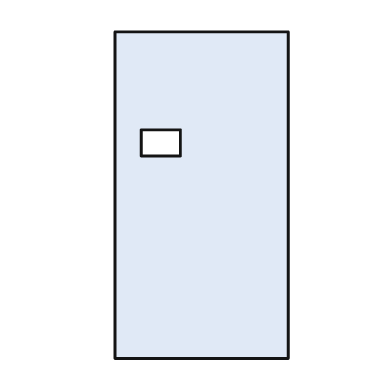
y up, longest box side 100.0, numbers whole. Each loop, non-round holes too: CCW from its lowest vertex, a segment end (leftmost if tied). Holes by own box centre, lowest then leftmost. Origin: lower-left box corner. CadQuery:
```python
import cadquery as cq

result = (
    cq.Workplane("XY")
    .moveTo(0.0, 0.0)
    .lineTo(53.0, 0.0)
    .lineTo(53.0, 100.0)
    .lineTo(0.0, 100.0)
    .close()
    .moveTo(8.0, 62.0)
    .lineTo(20.0, 62.0)
    .lineTo(20.0, 70.0)
    .lineTo(8.0, 70.0)
    .close()
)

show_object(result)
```